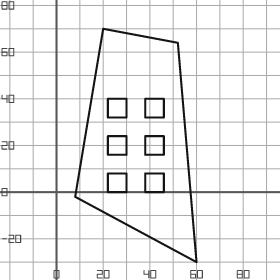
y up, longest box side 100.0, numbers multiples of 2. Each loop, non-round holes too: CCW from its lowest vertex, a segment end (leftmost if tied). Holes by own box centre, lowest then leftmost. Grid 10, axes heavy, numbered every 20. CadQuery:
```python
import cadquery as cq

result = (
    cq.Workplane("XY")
    .moveTo(60.0, -30.0)
    .lineTo(52.0, 64.0)
    .lineTo(20.0, 70.0)
    .lineTo(8.0, -2.0)
    .close()
    .moveTo(22.0, 0.0)
    .lineTo(30.0, 0.0)
    .lineTo(30.0, 8.0)
    .lineTo(22.0, 8.0)
    .close()
    .moveTo(38.0, 0.0)
    .lineTo(46.0, 0.0)
    .lineTo(46.0, 8.0)
    .lineTo(38.0, 8.0)
    .close()
    .moveTo(22.0, 16.0)
    .lineTo(30.0, 16.0)
    .lineTo(30.0, 24.0)
    .lineTo(22.0, 24.0)
    .close()
    .moveTo(38.0, 16.0)
    .lineTo(46.0, 16.0)
    .lineTo(46.0, 24.0)
    .lineTo(38.0, 24.0)
    .close()
    .moveTo(22.0, 32.0)
    .lineTo(30.0, 32.0)
    .lineTo(30.0, 40.0)
    .lineTo(22.0, 40.0)
    .close()
    .moveTo(38.0, 32.0)
    .lineTo(46.0, 32.0)
    .lineTo(46.0, 40.0)
    .lineTo(38.0, 40.0)
    .close()
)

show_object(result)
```